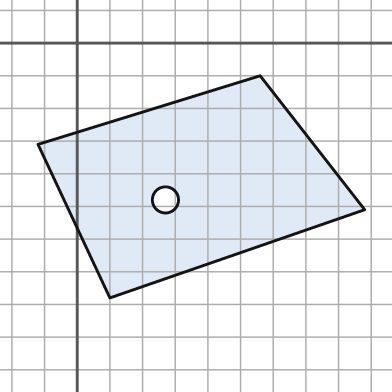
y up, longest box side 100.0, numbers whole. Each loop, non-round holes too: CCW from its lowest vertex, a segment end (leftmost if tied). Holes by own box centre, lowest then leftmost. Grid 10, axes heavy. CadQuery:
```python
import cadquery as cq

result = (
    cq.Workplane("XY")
    .moveTo(10.0, -78.0)
    .lineTo(88.0, -51.0)
    .lineTo(56.0, -10.0)
    .lineTo(-12.0, -31.0)
    .close()
    .moveTo(27.0, -48.0)
    .circle(4.0)
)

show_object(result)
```